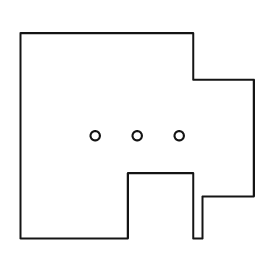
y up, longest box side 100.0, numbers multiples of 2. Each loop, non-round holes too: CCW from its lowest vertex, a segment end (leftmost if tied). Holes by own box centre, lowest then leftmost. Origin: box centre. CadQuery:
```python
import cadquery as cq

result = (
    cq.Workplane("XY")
    .moveTo(-50.0, -44.0)
    .lineTo(-4.0, -44.0)
    .lineTo(-4.0, -16.0)
    .lineTo(24.0, -16.0)
    .lineTo(24.0, -44.0)
    .lineTo(28.0, -44.0)
    .lineTo(28.0, -26.0)
    .lineTo(50.0, -26.0)
    .lineTo(50.0, 24.0)
    .lineTo(24.0, 24.0)
    .lineTo(24.0, 44.0)
    .lineTo(-50.0, 44.0)
    .close()
    .moveTo(-18.0, 0.0)
    .circle(2.0)
    .moveTo(0.0, 0.0)
    .circle(2.0)
    .moveTo(18.0, 0.0)
    .circle(2.0)
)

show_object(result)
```